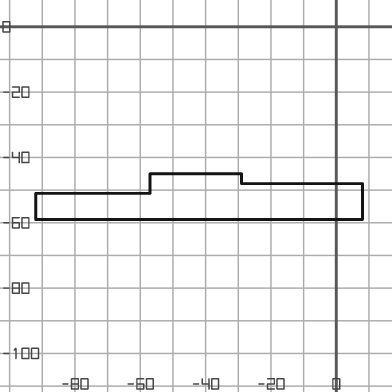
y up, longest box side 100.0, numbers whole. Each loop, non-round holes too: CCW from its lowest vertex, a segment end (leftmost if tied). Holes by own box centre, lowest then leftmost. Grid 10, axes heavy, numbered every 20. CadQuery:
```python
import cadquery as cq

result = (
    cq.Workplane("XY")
    .moveTo(-92.0, -59.0)
    .lineTo(8.0, -59.0)
    .lineTo(8.0, -48.0)
    .lineTo(-29.0, -48.0)
    .lineTo(-29.0, -45.0)
    .lineTo(-57.0, -45.0)
    .lineTo(-57.0, -51.0)
    .lineTo(-92.0, -51.0)
    .close()
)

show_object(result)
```